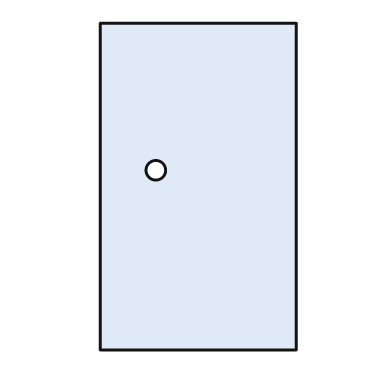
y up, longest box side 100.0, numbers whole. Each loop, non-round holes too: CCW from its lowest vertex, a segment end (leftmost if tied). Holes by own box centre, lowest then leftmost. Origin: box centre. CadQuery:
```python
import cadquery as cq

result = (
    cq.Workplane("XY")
    .moveTo(-30.0, -50.0)
    .lineTo(30.0, -50.0)
    .lineTo(30.0, 50.0)
    .lineTo(-30.0, 50.0)
    .close()
    .moveTo(-13.0, 5.0)
    .circle(3.0)
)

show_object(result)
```